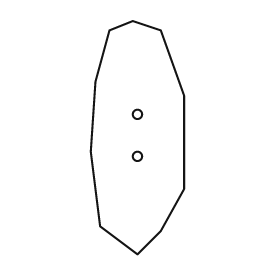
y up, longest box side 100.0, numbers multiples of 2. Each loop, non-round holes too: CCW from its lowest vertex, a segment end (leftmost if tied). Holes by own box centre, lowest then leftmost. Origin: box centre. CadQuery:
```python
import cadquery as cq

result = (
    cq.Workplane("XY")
    .moveTo(0.0, -50.0)
    .lineTo(10.0, -40.0)
    .lineTo(20.0, -22.0)
    .lineTo(20.0, 18.0)
    .lineTo(10.0, 46.0)
    .lineTo(-2.0, 50.0)
    .lineTo(-12.0, 46.0)
    .lineTo(-18.0, 24.0)
    .lineTo(-20.0, -6.0)
    .lineTo(-16.0, -38.0)
    .close()
    .moveTo(0.0, -8.0)
    .circle(2.0)
    .moveTo(0.0, 10.0)
    .circle(2.0)
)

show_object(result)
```